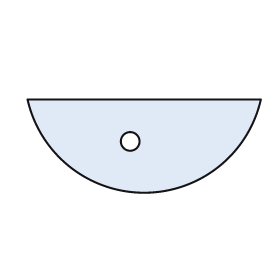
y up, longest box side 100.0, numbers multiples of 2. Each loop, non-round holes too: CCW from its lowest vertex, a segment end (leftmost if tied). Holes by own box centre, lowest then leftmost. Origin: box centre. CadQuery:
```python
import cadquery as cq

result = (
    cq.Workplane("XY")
    .moveTo(-50.0, 20.0)
    .threePointArc((0.0, -20.0), (50.0, 20.0))
    .close()
    .moveTo(-6.0, 2.0)
    .circle(4.0)
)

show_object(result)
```